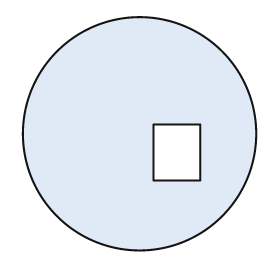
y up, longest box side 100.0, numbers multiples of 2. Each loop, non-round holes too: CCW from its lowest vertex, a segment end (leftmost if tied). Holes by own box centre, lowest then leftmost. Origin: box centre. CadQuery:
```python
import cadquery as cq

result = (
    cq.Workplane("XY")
    .moveTo(0.0, 0.0)
    .circle(50.0)
    .moveTo(6.0, -20.0)
    .lineTo(26.0, -20.0)
    .lineTo(26.0, 4.0)
    .lineTo(6.0, 4.0)
    .close()
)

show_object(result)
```